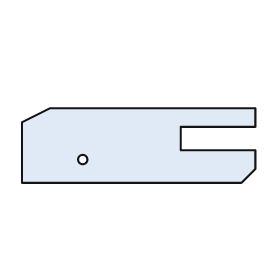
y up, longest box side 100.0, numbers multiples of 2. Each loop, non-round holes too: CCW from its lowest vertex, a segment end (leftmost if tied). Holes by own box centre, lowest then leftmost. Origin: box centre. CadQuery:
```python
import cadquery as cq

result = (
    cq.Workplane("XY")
    .moveTo(-50.0, -16.0)
    .lineTo(44.0, -16.0)
    .lineTo(50.0, -10.0)
    .lineTo(50.0, -2.0)
    .lineTo(18.0, -2.0)
    .lineTo(18.0, 8.0)
    .lineTo(50.0, 8.0)
    .lineTo(50.0, 16.0)
    .lineTo(-38.0, 16.0)
    .lineTo(-50.0, 10.0)
    .close()
    .moveTo(-24.0, -6.0)
    .circle(2.0)
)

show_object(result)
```